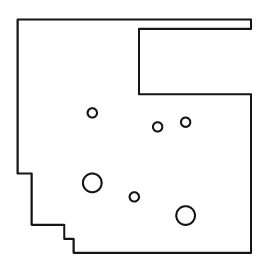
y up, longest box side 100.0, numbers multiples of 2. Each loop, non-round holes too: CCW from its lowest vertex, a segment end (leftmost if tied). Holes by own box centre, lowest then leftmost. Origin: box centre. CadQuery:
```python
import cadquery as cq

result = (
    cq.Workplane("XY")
    .moveTo(-26.0, -50.0)
    .lineTo(50.0, -50.0)
    .lineTo(50.0, 18.0)
    .lineTo(2.0, 18.0)
    .lineTo(2.0, 46.0)
    .lineTo(50.0, 46.0)
    .lineTo(50.0, 50.0)
    .lineTo(-50.0, 50.0)
    .lineTo(-50.0, -16.0)
    .lineTo(-44.0, -16.0)
    .lineTo(-44.0, -38.0)
    .lineTo(-30.0, -38.0)
    .lineTo(-30.0, -44.0)
    .lineTo(-26.0, -44.0)
    .close()
    .moveTo(22.0, -34.0)
    .circle(4.0)
    .moveTo(0.0, -26.0)
    .circle(2.0)
    .moveTo(-18.0, -20.0)
    .circle(4.0)
    .moveTo(10.0, 4.0)
    .circle(2.0)
    .moveTo(22.0, 6.0)
    .circle(2.0)
    .moveTo(-18.0, 10.0)
    .circle(2.0)
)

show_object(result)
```